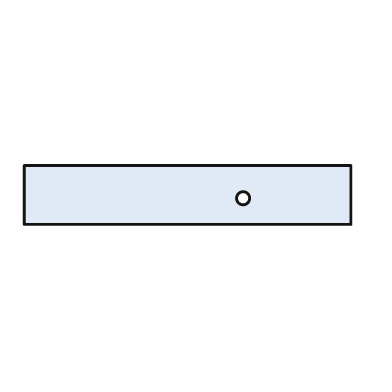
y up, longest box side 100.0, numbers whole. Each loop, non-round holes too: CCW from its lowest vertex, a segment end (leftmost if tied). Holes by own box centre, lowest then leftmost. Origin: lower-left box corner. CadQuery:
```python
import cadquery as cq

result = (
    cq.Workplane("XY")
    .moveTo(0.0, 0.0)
    .lineTo(100.0, 0.0)
    .lineTo(100.0, 18.0)
    .lineTo(0.0, 18.0)
    .close()
    .moveTo(67.0, 8.0)
    .circle(2.0)
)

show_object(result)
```